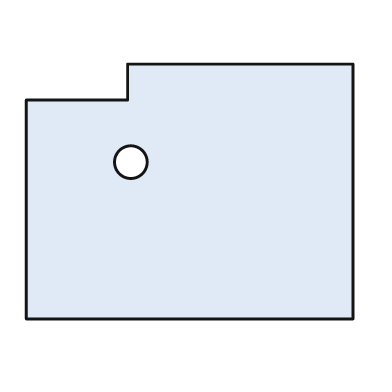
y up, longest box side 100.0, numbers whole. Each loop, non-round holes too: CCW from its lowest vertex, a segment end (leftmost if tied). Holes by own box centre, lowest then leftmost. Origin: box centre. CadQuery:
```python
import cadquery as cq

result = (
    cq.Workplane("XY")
    .moveTo(-50.0, -39.0)
    .lineTo(50.0, -39.0)
    .lineTo(50.0, 39.0)
    .lineTo(-19.0, 39.0)
    .lineTo(-19.0, 28.0)
    .lineTo(-50.0, 28.0)
    .close()
    .moveTo(-18.0, 9.0)
    .circle(5.0)
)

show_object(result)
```